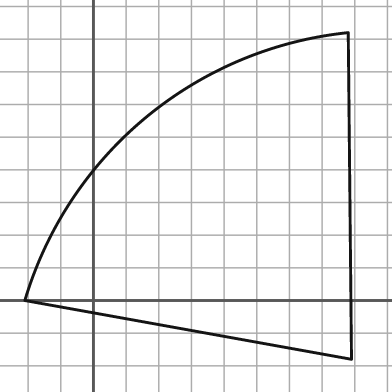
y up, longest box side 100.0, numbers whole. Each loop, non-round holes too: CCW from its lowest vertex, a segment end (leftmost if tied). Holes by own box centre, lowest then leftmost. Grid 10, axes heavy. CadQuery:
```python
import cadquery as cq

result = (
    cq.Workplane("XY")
    .moveTo(79.0, -18.0)
    .lineTo(78.0, 82.0)
    .threePointArc((16.0, 56.0), (-21.0, 0.0))
    .close()
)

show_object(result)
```